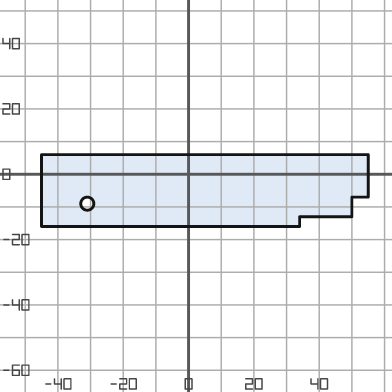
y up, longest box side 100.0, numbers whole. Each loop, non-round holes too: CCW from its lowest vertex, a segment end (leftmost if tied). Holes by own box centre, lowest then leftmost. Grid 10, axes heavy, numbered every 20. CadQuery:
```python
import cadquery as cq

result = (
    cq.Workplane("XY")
    .moveTo(-45.0, -16.0)
    .lineTo(34.0, -16.0)
    .lineTo(34.0, -13.0)
    .lineTo(50.0, -13.0)
    .lineTo(50.0, -7.0)
    .lineTo(55.0, -7.0)
    .lineTo(55.0, 6.0)
    .lineTo(-45.0, 6.0)
    .close()
    .moveTo(-31.0, -9.0)
    .circle(2.0)
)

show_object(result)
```